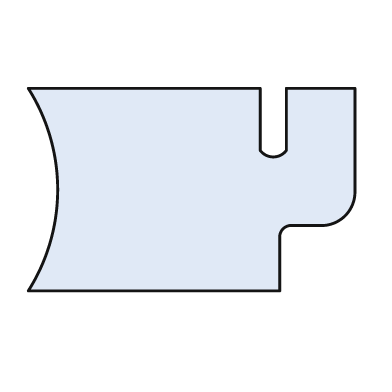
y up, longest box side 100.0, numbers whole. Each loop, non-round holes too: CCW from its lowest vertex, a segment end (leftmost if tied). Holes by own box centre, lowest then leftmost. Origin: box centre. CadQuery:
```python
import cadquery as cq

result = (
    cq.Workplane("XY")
    .moveTo(-50.0, -31.0)
    .lineTo(27.0, -31.0)
    .lineTo(27.0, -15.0)
    .threePointArc((28.0, -12.0), (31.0, -11.0))
    .lineTo(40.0, -11.0)
    .threePointArc((47.0, -8.0), (50.0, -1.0))
    .lineTo(50.0, 31.0)
    .lineTo(29.0, 31.0)
    .lineTo(29.0, 12.0)
    .threePointArc((25.0, 10.0), (21.0, 12.0))
    .lineTo(21.0, 31.0)
    .lineTo(-50.0, 31.0)
    .threePointArc((-41.0, 0.0), (-50.0, -31.0))
    .close()
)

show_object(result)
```